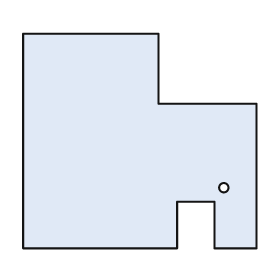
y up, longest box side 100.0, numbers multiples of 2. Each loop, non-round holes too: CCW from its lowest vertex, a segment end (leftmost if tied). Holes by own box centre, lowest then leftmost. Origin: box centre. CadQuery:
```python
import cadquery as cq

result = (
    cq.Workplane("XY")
    .moveTo(-50.0, -46.0)
    .lineTo(16.0, -46.0)
    .lineTo(16.0, -26.0)
    .lineTo(32.0, -26.0)
    .lineTo(32.0, -46.0)
    .lineTo(50.0, -46.0)
    .lineTo(50.0, 16.0)
    .lineTo(8.0, 16.0)
    .lineTo(8.0, 46.0)
    .lineTo(-50.0, 46.0)
    .close()
    .moveTo(36.0, -20.0)
    .circle(2.0)
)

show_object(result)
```